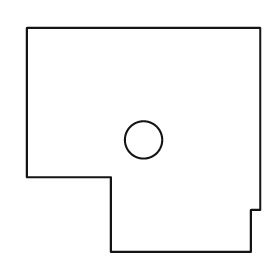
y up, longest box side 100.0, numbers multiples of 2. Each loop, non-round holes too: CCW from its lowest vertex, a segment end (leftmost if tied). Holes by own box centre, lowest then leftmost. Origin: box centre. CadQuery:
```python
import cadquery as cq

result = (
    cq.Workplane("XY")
    .moveTo(-14.0, -48.0)
    .lineTo(46.0, -48.0)
    .lineTo(46.0, -30.0)
    .lineTo(50.0, -30.0)
    .lineTo(50.0, 48.0)
    .lineTo(-50.0, 48.0)
    .lineTo(-50.0, -16.0)
    .lineTo(-14.0, -16.0)
    .close()
    .moveTo(0.0, 0.0)
    .circle(8.0)
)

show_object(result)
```